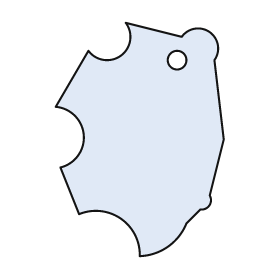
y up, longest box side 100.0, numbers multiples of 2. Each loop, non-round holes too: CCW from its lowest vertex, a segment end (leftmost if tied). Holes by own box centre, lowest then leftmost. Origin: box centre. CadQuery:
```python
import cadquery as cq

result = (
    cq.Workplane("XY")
    .moveTo(0.0, -50.0)
    .threePointArc((12.0, -46.0), (20.0, -36.0))
    .lineTo(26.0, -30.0)
    .threePointArc((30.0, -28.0), (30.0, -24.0))
    .lineTo(36.0, 0.0)
    .lineTo(32.0, 34.0)
    .threePointArc((30.0, 46.0), (18.0, 44.0))
    .lineTo(-6.0, 50.0)
    .threePointArc((-8.0, 36.0), (-22.0, 38.0))
    .lineTo(-36.0, 14.0)
    .threePointArc((-24.0, 2.0), (-34.0, -12.0))
    .lineTo(-26.0, -32.0)
    .threePointArc((-8.0, -34.0), (0.0, -50.0))
    .close()
    .moveTo(16.0, 34.0)
    .circle(4.0)
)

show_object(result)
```